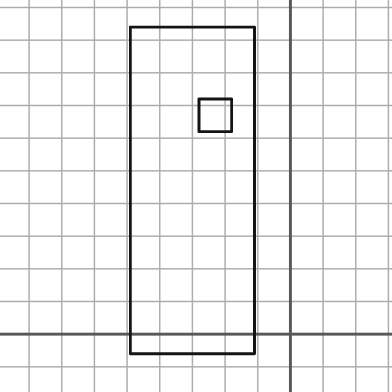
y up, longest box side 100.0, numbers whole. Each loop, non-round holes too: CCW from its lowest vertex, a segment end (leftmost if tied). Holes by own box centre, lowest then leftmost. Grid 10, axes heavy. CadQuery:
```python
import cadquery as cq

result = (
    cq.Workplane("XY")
    .moveTo(-49.0, -6.0)
    .lineTo(-11.0, -6.0)
    .lineTo(-11.0, 94.0)
    .lineTo(-49.0, 94.0)
    .close()
    .moveTo(-28.0, 62.0)
    .lineTo(-18.0, 62.0)
    .lineTo(-18.0, 72.0)
    .lineTo(-28.0, 72.0)
    .close()
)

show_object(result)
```